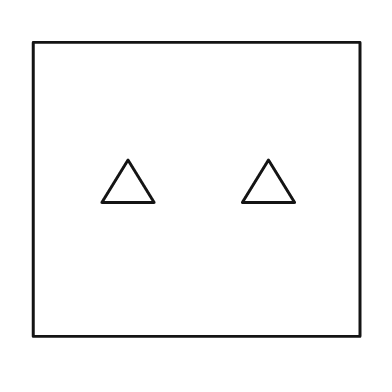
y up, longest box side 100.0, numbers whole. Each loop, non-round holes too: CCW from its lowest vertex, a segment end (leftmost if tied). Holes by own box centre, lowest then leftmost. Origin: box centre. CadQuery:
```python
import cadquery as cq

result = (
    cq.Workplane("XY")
    .moveTo(-50.0, -45.0)
    .lineTo(50.0, -45.0)
    .lineTo(50.0, 45.0)
    .lineTo(-50.0, 45.0)
    .close()
    .moveTo(-29.0, -4.0)
    .lineTo(-13.0, -4.0)
    .lineTo(-21.0, 9.0)
    .close()
    .moveTo(14.0, -4.0)
    .lineTo(30.0, -4.0)
    .lineTo(22.0, 9.0)
    .close()
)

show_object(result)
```